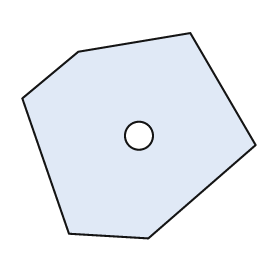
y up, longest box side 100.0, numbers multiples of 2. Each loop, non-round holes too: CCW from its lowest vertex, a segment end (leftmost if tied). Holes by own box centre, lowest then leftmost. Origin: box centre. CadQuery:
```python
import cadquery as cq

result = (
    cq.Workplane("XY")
    .moveTo(4.0, -44.0)
    .lineTo(50.0, -4.0)
    .lineTo(22.0, 44.0)
    .lineTo(-26.0, 36.0)
    .lineTo(-50.0, 16.0)
    .lineTo(-30.0, -42.0)
    .close()
    .moveTo(0.0, 0.0)
    .circle(6.0)
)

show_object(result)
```